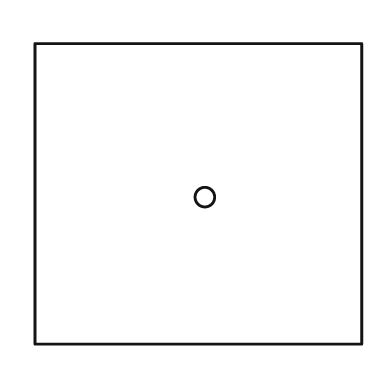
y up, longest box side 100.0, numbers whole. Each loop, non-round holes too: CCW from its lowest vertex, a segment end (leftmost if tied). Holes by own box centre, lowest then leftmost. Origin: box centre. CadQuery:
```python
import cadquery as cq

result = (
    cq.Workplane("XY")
    .moveTo(-50.0, -46.0)
    .lineTo(50.0, -46.0)
    .lineTo(50.0, 46.0)
    .lineTo(-50.0, 46.0)
    .close()
    .moveTo(2.0, -1.0)
    .circle(3.0)
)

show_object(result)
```